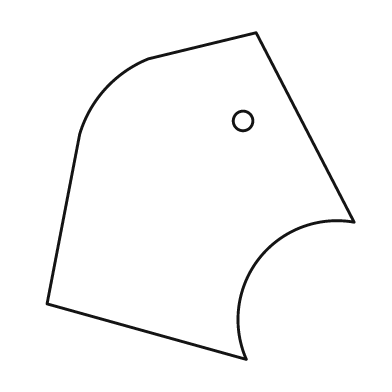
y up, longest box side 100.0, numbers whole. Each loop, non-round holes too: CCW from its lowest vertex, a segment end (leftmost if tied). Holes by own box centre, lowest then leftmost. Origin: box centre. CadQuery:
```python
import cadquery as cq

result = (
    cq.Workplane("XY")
    .moveTo(14.0, -50.0)
    .threePointArc((18.0, -19.0), (47.0, -8.0))
    .lineTo(17.0, 50.0)
    .lineTo(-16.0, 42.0)
    .threePointArc((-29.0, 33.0), (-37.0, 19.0))
    .lineTo(-47.0, -33.0)
    .close()
    .moveTo(13.0, 23.0)
    .circle(3.0)
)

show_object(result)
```